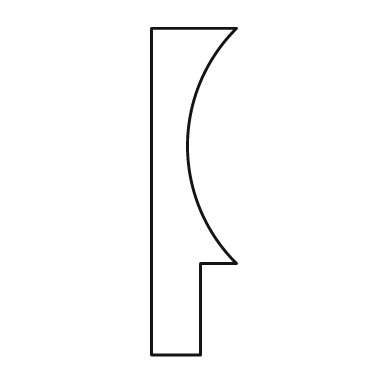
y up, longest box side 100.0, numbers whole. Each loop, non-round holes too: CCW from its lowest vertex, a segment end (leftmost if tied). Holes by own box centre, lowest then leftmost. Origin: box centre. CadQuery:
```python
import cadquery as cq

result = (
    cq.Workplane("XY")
    .moveTo(-13.0, -50.0)
    .lineTo(2.0, -50.0)
    .lineTo(2.0, -22.0)
    .lineTo(13.0, -22.0)
    .threePointArc((-2.0, 14.0), (13.0, 50.0))
    .lineTo(-13.0, 50.0)
    .close()
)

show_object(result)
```